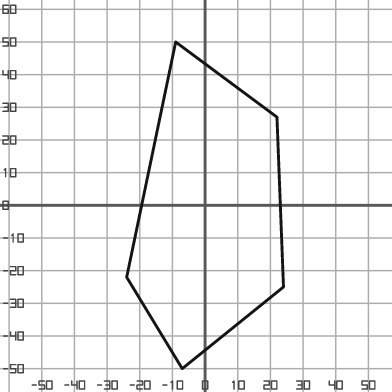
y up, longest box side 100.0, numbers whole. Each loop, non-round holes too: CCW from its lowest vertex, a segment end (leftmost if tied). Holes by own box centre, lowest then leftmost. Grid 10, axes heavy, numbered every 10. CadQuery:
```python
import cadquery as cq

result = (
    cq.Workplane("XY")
    .moveTo(-7.0, -50.0)
    .lineTo(24.0, -25.0)
    .lineTo(22.0, 27.0)
    .lineTo(-9.0, 50.0)
    .lineTo(-24.0, -22.0)
    .close()
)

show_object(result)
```